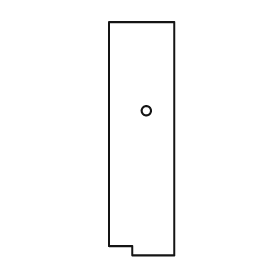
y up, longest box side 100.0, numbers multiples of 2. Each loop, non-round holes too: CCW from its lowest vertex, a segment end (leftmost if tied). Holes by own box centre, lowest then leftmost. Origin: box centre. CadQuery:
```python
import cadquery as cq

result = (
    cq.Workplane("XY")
    .moveTo(-4.0, -50.0)
    .lineTo(14.0, -50.0)
    .lineTo(14.0, 50.0)
    .lineTo(-14.0, 50.0)
    .lineTo(-14.0, -46.0)
    .lineTo(-4.0, -46.0)
    .close()
    .moveTo(2.0, 12.0)
    .circle(2.0)
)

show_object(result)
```